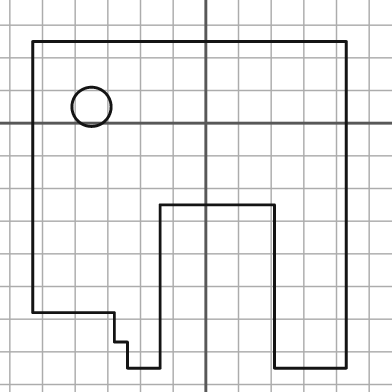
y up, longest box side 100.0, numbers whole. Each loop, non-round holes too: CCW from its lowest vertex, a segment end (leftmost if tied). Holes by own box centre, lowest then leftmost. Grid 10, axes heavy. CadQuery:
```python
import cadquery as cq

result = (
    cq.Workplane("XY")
    .moveTo(-24.0, -75.0)
    .lineTo(-14.0, -75.0)
    .lineTo(-14.0, -25.0)
    .lineTo(21.0, -25.0)
    .lineTo(21.0, -75.0)
    .lineTo(43.0, -75.0)
    .lineTo(43.0, 25.0)
    .lineTo(-53.0, 25.0)
    .lineTo(-53.0, -58.0)
    .lineTo(-28.0, -58.0)
    .lineTo(-28.0, -67.0)
    .lineTo(-24.0, -67.0)
    .close()
    .moveTo(-35.0, 5.0)
    .circle(6.0)
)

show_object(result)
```